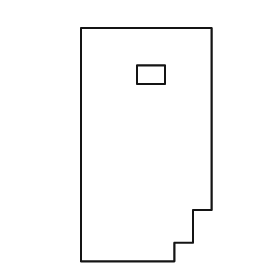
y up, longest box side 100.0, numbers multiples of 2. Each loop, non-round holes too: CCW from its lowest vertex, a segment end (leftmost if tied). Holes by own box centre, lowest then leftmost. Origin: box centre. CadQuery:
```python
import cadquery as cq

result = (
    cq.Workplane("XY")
    .moveTo(-28.0, -50.0)
    .lineTo(12.0, -50.0)
    .lineTo(12.0, -42.0)
    .lineTo(20.0, -42.0)
    .lineTo(20.0, -28.0)
    .lineTo(28.0, -28.0)
    .lineTo(28.0, 50.0)
    .lineTo(-28.0, 50.0)
    .close()
    .moveTo(-4.0, 26.0)
    .lineTo(8.0, 26.0)
    .lineTo(8.0, 34.0)
    .lineTo(-4.0, 34.0)
    .close()
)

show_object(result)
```